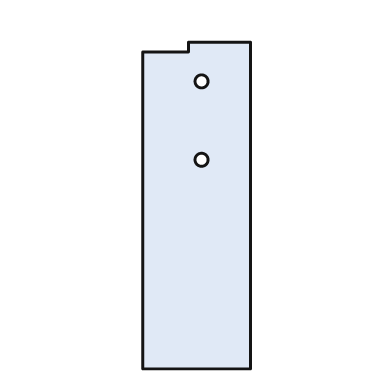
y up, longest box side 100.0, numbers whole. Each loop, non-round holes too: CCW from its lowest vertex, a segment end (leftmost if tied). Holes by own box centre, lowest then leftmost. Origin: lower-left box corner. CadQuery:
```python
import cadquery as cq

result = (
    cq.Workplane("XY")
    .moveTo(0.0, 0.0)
    .lineTo(33.0, 0.0)
    .lineTo(33.0, 100.0)
    .lineTo(14.0, 100.0)
    .lineTo(14.0, 97.0)
    .lineTo(0.0, 97.0)
    .close()
    .moveTo(18.0, 64.0)
    .circle(2.0)
    .moveTo(18.0, 88.0)
    .circle(2.0)
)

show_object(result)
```